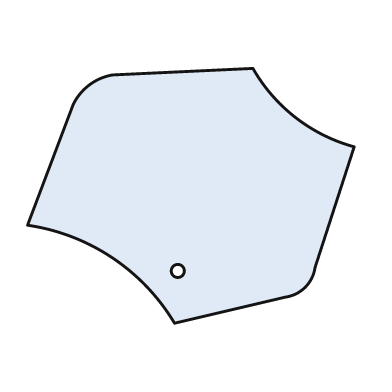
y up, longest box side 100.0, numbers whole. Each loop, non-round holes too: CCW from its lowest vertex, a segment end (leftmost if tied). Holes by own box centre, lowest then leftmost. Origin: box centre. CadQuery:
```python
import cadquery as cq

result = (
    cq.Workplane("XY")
    .moveTo(-5.0, -39.0)
    .lineTo(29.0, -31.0)
    .threePointArc((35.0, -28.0), (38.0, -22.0))
    .lineTo(50.0, 15.0)
    .threePointArc((32.0, 24.0), (19.0, 39.0))
    .lineTo(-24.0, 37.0)
    .threePointArc((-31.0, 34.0), (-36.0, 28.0))
    .lineTo(-50.0, -9.0)
    .threePointArc((-24.0, -19.0), (-5.0, -39.0))
    .close()
    .moveTo(-4.0, -23.0)
    .circle(2.0)
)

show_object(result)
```